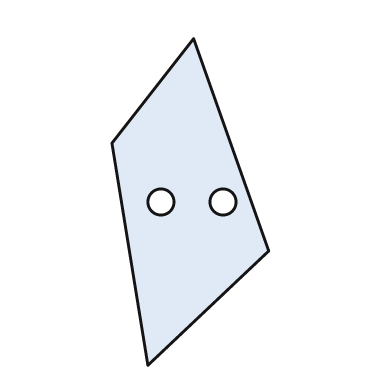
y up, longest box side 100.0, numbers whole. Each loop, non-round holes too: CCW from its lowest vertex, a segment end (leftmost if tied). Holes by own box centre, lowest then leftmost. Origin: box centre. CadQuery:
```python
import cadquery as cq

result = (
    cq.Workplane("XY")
    .moveTo(-13.0, -50.0)
    .lineTo(24.0, -15.0)
    .lineTo(1.0, 50.0)
    .lineTo(-24.0, 18.0)
    .close()
    .moveTo(-9.0, 0.0)
    .circle(4.0)
    .moveTo(10.0, 0.0)
    .circle(4.0)
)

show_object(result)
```